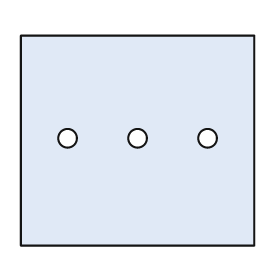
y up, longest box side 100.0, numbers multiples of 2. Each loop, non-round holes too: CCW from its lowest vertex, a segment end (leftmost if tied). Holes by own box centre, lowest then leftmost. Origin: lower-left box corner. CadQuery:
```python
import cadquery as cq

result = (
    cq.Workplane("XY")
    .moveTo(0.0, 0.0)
    .lineTo(100.0, 0.0)
    .lineTo(100.0, 90.0)
    .lineTo(0.0, 90.0)
    .close()
    .moveTo(20.0, 46.0)
    .circle(4.0)
    .moveTo(50.0, 46.0)
    .circle(4.0)
    .moveTo(80.0, 46.0)
    .circle(4.0)
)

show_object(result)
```